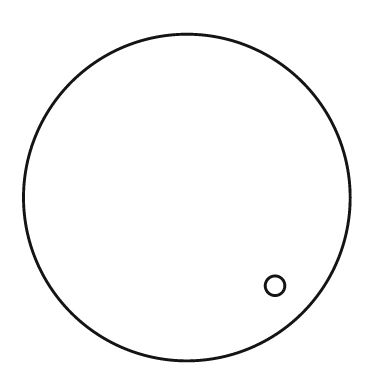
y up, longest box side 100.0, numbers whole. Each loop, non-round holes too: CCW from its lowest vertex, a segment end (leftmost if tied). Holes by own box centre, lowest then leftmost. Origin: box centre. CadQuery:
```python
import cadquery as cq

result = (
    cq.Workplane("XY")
    .moveTo(0.0, 0.0)
    .circle(50.0)
    .moveTo(27.0, -27.0)
    .circle(3.0)
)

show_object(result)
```